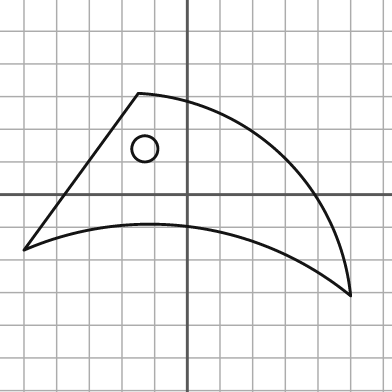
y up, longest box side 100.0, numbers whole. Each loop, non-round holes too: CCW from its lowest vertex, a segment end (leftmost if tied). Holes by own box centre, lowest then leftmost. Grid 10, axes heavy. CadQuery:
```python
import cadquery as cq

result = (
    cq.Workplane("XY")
    .moveTo(50.0, -31.0)
    .threePointArc((29.0, 12.0), (-15.0, 31.0))
    .lineTo(-50.0, -17.0)
    .threePointArc((2.0, -10.0), (50.0, -31.0))
    .close()
    .moveTo(-13.0, 14.0)
    .circle(4.0)
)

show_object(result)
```